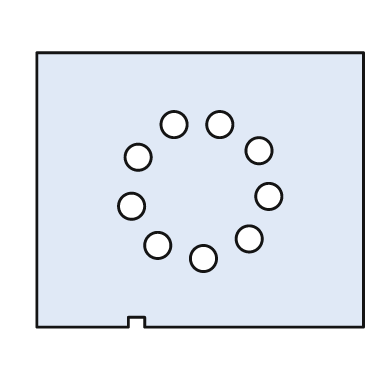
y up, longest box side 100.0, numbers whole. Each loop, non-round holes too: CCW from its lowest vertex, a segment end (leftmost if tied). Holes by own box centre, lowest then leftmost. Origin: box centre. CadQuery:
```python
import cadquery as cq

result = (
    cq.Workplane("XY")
    .moveTo(-50.0, -42.0)
    .lineTo(-22.0, -42.0)
    .lineTo(-22.0, -39.0)
    .lineTo(-17.0, -39.0)
    .lineTo(-17.0, -42.0)
    .lineTo(50.0, -42.0)
    .lineTo(50.0, 42.0)
    .lineTo(-50.0, 42.0)
    .close()
    .moveTo(1.0, -21.0)
    .circle(4.0)
    .moveTo(-13.0, -17.0)
    .circle(4.0)
    .moveTo(15.0, -15.0)
    .circle(4.0)
    .moveTo(-21.0, -5.0)
    .circle(4.0)
    .moveTo(21.0, -2.0)
    .circle(4.0)
    .moveTo(-19.0, 10.0)
    .circle(4.0)
    .moveTo(18.0, 12.0)
    .circle(4.0)
    .moveTo(-8.0, 20.0)
    .circle(4.0)
    .moveTo(6.0, 20.0)
    .circle(4.0)
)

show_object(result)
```